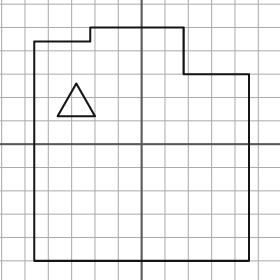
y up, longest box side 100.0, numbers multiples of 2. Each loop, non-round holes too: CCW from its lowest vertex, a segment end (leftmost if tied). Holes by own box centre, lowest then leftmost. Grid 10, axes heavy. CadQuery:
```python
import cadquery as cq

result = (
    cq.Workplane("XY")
    .moveTo(-46.0, -50.0)
    .lineTo(46.0, -50.0)
    .lineTo(46.0, 30.0)
    .lineTo(18.0, 30.0)
    .lineTo(18.0, 50.0)
    .lineTo(-22.0, 50.0)
    .lineTo(-22.0, 44.0)
    .lineTo(-46.0, 44.0)
    .close()
    .moveTo(-36.0, 12.0)
    .lineTo(-20.0, 12.0)
    .lineTo(-28.0, 26.0)
    .close()
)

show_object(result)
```